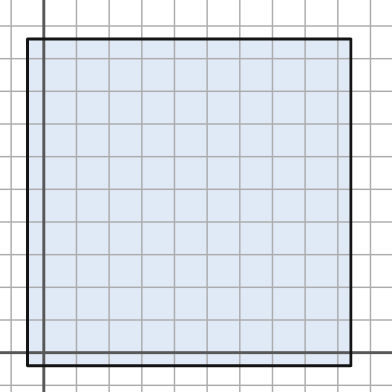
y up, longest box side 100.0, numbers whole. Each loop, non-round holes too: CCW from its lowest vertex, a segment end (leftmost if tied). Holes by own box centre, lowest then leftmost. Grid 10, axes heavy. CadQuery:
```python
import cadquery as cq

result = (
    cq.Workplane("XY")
    .moveTo(-5.0, -4.0)
    .lineTo(94.0, -4.0)
    .lineTo(94.0, 96.0)
    .lineTo(-5.0, 96.0)
    .close()
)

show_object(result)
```